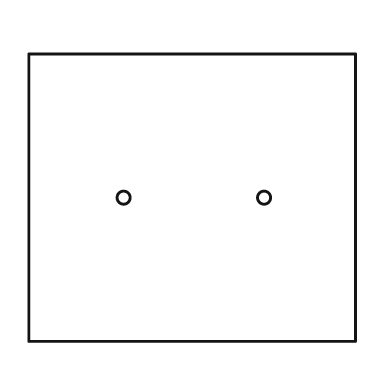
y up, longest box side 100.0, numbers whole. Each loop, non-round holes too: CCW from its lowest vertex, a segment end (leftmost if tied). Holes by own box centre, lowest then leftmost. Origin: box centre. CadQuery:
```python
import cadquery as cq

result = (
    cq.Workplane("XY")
    .moveTo(-50.0, -44.0)
    .lineTo(50.0, -44.0)
    .lineTo(50.0, 44.0)
    .lineTo(-50.0, 44.0)
    .close()
    .moveTo(-21.0, 0.0)
    .circle(2.0)
    .moveTo(22.0, 0.0)
    .circle(2.0)
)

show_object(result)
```